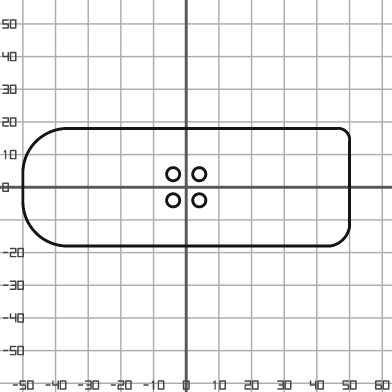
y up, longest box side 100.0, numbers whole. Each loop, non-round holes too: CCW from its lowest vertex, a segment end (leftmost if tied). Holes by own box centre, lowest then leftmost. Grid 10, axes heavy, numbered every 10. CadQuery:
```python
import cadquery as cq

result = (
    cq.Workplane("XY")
    .moveTo(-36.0, -18.0)
    .lineTo(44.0, -18.0)
    .threePointArc((48.0, -16.0), (50.0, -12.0))
    .lineTo(50.0, 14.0)
    .threePointArc((49.0, 17.0), (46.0, 18.0))
    .lineTo(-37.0, 18.0)
    .threePointArc((-46.0, 14.0), (-50.0, 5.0))
    .lineTo(-50.0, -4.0)
    .threePointArc((-46.0, -14.0), (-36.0, -18.0))
    .close()
    .moveTo(-4.0, -4.0)
    .circle(2.0)
    .moveTo(4.0, -4.0)
    .circle(2.0)
    .moveTo(-4.0, 4.0)
    .circle(2.0)
    .moveTo(4.0, 4.0)
    .circle(2.0)
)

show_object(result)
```